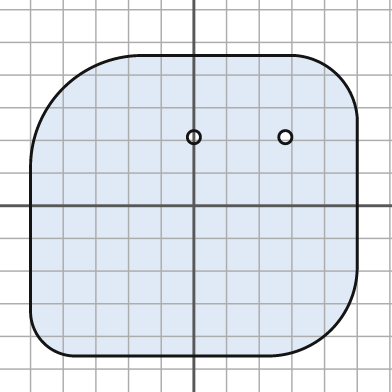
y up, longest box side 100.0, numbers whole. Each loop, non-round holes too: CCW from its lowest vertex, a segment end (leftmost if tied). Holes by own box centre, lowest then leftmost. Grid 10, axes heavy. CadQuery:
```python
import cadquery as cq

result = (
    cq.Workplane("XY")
    .moveTo(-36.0, -46.0)
    .lineTo(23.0, -46.0)
    .threePointArc((42.0, -38.0), (50.0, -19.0))
    .lineTo(50.0, 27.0)
    .threePointArc((44.0, 40.0), (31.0, 46.0))
    .lineTo(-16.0, 46.0)
    .threePointArc((-40.0, 36.0), (-50.0, 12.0))
    .lineTo(-50.0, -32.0)
    .threePointArc((-46.0, -42.0), (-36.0, -46.0))
    .close()
    .moveTo(0.0, 21.0)
    .circle(2.0)
    .moveTo(28.0, 21.0)
    .circle(2.0)
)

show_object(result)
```